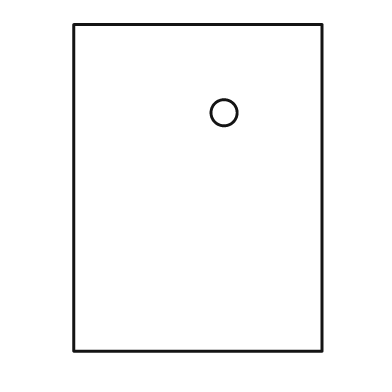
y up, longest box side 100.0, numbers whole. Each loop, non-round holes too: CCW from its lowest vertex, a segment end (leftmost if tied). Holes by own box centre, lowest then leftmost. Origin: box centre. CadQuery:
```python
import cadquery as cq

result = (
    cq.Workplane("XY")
    .moveTo(-38.0, -50.0)
    .lineTo(38.0, -50.0)
    .lineTo(38.0, 50.0)
    .lineTo(-38.0, 50.0)
    .close()
    .moveTo(8.0, 23.0)
    .circle(4.0)
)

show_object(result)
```